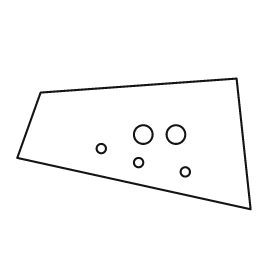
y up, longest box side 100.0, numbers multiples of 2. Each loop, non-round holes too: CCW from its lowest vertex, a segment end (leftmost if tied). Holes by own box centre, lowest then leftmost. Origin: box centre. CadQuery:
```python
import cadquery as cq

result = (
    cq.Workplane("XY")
    .moveTo(50.0, -28.0)
    .lineTo(44.0, 28.0)
    .lineTo(-40.0, 22.0)
    .lineTo(-50.0, -6.0)
    .close()
    .moveTo(22.0, -12.0)
    .circle(2.0)
    .moveTo(2.0, -8.0)
    .circle(2.0)
    .moveTo(-14.0, -2.0)
    .circle(2.0)
    .moveTo(4.0, 4.0)
    .circle(4.0)
    .moveTo(18.0, 4.0)
    .circle(4.0)
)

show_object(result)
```